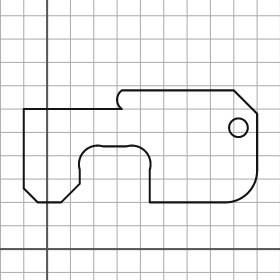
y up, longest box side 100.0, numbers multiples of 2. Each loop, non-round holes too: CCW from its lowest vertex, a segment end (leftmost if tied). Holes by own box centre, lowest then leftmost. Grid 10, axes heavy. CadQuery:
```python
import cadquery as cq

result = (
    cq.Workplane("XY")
    .moveTo(-4.0, 20.0)
    .lineTo(6.0, 20.0)
    .lineTo(14.0, 28.0)
    .lineTo(14.0, 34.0)
    .threePointArc((16.0, 42.0), (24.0, 44.0))
    .lineTo(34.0, 44.0)
    .threePointArc((42.0, 42.0), (44.0, 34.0))
    .lineTo(44.0, 20.0)
    .lineTo(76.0, 20.0)
    .threePointArc((86.0, 24.0), (90.0, 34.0))
    .lineTo(90.0, 58.0)
    .lineTo(80.0, 68.0)
    .lineTo(32.0, 68.0)
    .threePointArc((30.0, 64.0), (32.0, 60.0))
    .lineTo(-10.0, 60.0)
    .lineTo(-10.0, 26.0)
    .close()
    .moveTo(82.0, 52.0)
    .circle(4.0)
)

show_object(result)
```